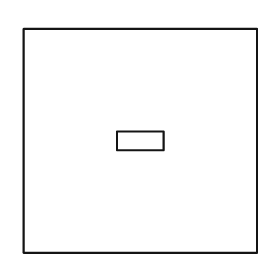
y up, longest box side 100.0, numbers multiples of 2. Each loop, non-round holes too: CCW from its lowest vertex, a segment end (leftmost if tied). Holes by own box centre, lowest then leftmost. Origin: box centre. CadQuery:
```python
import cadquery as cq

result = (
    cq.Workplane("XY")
    .moveTo(-50.0, -48.0)
    .lineTo(50.0, -48.0)
    .lineTo(50.0, 48.0)
    .lineTo(-50.0, 48.0)
    .close()
    .moveTo(-10.0, -4.0)
    .lineTo(10.0, -4.0)
    .lineTo(10.0, 4.0)
    .lineTo(-10.0, 4.0)
    .close()
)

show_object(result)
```